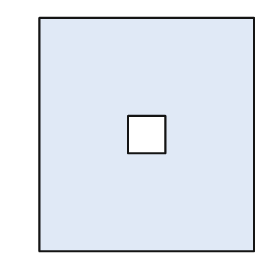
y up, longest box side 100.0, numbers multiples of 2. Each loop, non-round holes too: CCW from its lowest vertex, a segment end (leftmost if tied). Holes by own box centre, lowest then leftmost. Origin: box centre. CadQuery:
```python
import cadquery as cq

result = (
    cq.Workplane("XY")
    .moveTo(-46.0, -50.0)
    .lineTo(46.0, -50.0)
    .lineTo(46.0, 50.0)
    .lineTo(-46.0, 50.0)
    .close()
    .moveTo(-8.0, -8.0)
    .lineTo(8.0, -8.0)
    .lineTo(8.0, 8.0)
    .lineTo(-8.0, 8.0)
    .close()
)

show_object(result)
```